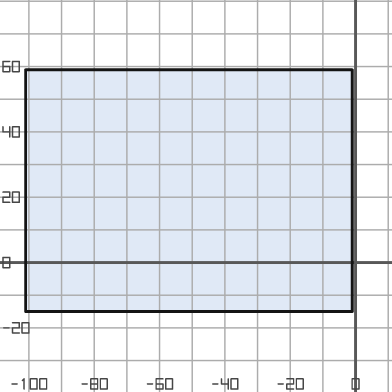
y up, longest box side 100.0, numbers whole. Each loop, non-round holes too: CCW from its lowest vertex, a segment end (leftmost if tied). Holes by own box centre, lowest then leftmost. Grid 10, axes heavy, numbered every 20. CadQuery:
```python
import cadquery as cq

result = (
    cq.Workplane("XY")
    .moveTo(-101.0, -15.0)
    .lineTo(-1.0, -15.0)
    .lineTo(-1.0, 59.0)
    .lineTo(-101.0, 59.0)
    .close()
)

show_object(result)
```